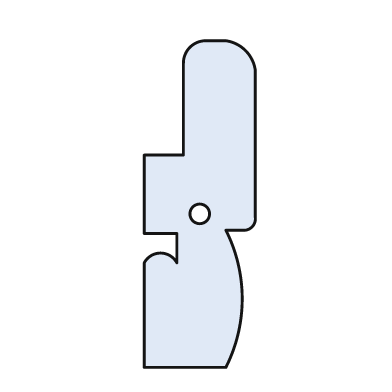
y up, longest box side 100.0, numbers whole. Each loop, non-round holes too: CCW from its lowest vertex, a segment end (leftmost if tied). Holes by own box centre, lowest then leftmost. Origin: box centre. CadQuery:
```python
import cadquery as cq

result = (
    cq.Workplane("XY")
    .moveTo(-17.0, -50.0)
    .lineTo(8.0, -50.0)
    .threePointArc((13.0, -29.0), (8.0, -8.0))
    .lineTo(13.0, -8.0)
    .threePointArc((16.0, -7.0), (17.0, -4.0))
    .lineTo(17.0, 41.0)
    .threePointArc((14.0, 47.0), (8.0, 50.0))
    .lineTo(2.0, 50.0)
    .threePointArc((-3.0, 48.0), (-5.0, 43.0))
    .lineTo(-5.0, 15.0)
    .lineTo(-17.0, 15.0)
    .lineTo(-17.0, -9.0)
    .lineTo(-7.0, -9.0)
    .lineTo(-7.0, -18.0)
    .threePointArc((-12.0, -15.0), (-17.0, -18.0))
    .close()
    .moveTo(0.0, -3.0)
    .circle(3.0)
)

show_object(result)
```